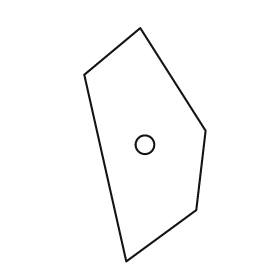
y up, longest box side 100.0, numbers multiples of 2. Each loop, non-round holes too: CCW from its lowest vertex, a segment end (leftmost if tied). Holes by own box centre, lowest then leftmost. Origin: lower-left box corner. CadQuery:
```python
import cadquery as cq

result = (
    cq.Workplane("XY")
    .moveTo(18.0, 0.0)
    .lineTo(48.0, 22.0)
    .lineTo(52.0, 56.0)
    .lineTo(24.0, 100.0)
    .lineTo(0.0, 80.0)
    .close()
    .moveTo(26.0, 50.0)
    .circle(4.0)
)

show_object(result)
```